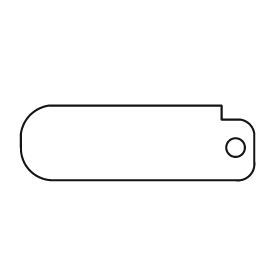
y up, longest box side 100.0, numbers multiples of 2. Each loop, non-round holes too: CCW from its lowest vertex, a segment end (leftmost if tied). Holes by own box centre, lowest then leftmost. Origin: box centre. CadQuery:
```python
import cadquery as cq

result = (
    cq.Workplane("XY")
    .moveTo(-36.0, -16.0)
    .lineTo(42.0, -16.0)
    .threePointArc((48.0, -14.0), (50.0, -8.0))
    .lineTo(50.0, 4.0)
    .threePointArc((48.0, 8.0), (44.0, 10.0))
    .lineTo(36.0, 10.0)
    .lineTo(36.0, 16.0)
    .lineTo(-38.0, 16.0)
    .threePointArc((-46.0, 12.0), (-50.0, 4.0))
    .lineTo(-50.0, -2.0)
    .threePointArc((-46.0, -12.0), (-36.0, -16.0))
    .close()
    .moveTo(42.0, -2.0)
    .circle(4.0)
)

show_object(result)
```